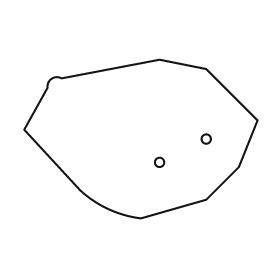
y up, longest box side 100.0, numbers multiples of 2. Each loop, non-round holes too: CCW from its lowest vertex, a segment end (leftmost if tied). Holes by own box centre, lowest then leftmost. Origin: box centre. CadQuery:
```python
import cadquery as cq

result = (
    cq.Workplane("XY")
    .moveTo(0.0, -34.0)
    .lineTo(28.0, -26.0)
    .lineTo(42.0, -12.0)
    .lineTo(50.0, 8.0)
    .lineTo(28.0, 30.0)
    .lineTo(8.0, 34.0)
    .lineTo(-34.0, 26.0)
    .threePointArc((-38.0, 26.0), (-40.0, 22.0))
    .lineTo(-50.0, 4.0)
    .lineTo(-26.0, -22.0)
    .threePointArc((-14.0, -30.0), (0.0, -34.0))
    .close()
    .moveTo(8.0, -10.0)
    .circle(2.0)
    .moveTo(28.0, 0.0)
    .circle(2.0)
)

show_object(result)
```